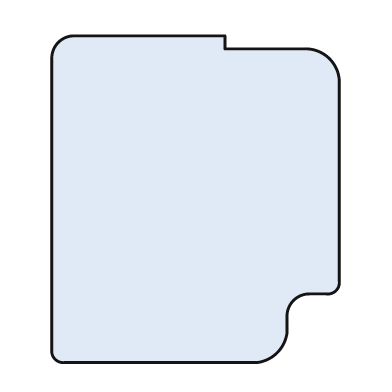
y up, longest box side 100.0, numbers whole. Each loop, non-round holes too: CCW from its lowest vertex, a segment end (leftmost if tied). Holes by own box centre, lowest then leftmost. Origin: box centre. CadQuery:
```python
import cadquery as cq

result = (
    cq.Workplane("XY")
    .moveTo(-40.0, -50.0)
    .lineTo(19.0, -50.0)
    .threePointArc((25.0, -47.0), (28.0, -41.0))
    .lineTo(28.0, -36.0)
    .threePointArc((30.0, -31.0), (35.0, -29.0))
    .lineTo(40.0, -29.0)
    .threePointArc((43.0, -28.0), (44.0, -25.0))
    .lineTo(44.0, 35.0)
    .threePointArc((41.0, 43.0), (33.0, 46.0))
    .lineTo(9.0, 46.0)
    .lineTo(9.0, 50.0)
    .lineTo(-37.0, 50.0)
    .threePointArc((-42.0, 48.0), (-44.0, 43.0))
    .lineTo(-44.0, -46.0)
    .threePointArc((-43.0, -49.0), (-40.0, -50.0))
    .close()
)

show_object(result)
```